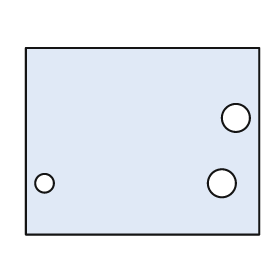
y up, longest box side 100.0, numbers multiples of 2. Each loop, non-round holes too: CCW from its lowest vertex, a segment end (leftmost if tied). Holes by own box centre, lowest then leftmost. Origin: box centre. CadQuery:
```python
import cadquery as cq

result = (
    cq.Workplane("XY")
    .moveTo(-50.0, -40.0)
    .lineTo(50.0, -40.0)
    .lineTo(50.0, 40.0)
    .lineTo(-50.0, 40.0)
    .close()
    .moveTo(-42.0, -18.0)
    .circle(4.0)
    .moveTo(34.0, -18.0)
    .circle(6.0)
    .moveTo(40.0, 10.0)
    .circle(6.0)
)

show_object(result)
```